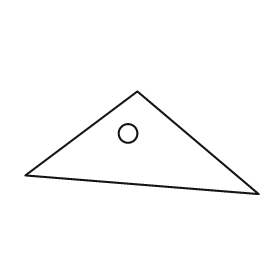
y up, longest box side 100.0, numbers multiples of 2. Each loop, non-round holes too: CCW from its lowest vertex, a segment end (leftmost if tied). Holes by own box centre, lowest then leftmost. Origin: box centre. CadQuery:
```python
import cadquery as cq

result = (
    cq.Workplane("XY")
    .moveTo(50.0, -22.0)
    .lineTo(-2.0, 22.0)
    .lineTo(-50.0, -14.0)
    .close()
    .moveTo(-6.0, 4.0)
    .circle(4.0)
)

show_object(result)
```